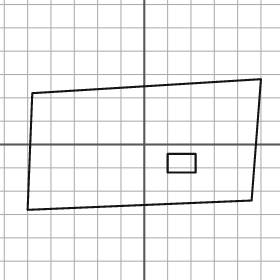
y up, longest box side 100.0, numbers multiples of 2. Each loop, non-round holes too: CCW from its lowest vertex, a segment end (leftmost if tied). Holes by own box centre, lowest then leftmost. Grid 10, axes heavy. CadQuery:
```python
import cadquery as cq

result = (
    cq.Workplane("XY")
    .moveTo(-50.0, -28.0)
    .lineTo(46.0, -24.0)
    .lineTo(50.0, 28.0)
    .lineTo(-48.0, 22.0)
    .close()
    .moveTo(10.0, -12.0)
    .lineTo(22.0, -12.0)
    .lineTo(22.0, -4.0)
    .lineTo(10.0, -4.0)
    .close()
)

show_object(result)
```